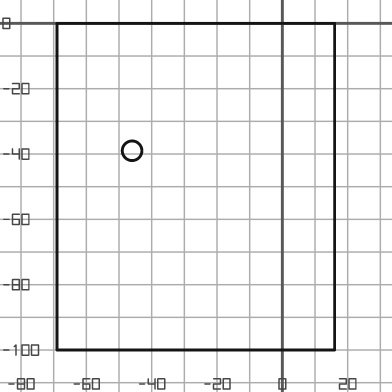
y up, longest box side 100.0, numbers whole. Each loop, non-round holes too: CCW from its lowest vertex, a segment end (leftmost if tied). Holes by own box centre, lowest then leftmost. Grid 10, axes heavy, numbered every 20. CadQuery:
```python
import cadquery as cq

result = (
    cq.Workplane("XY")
    .moveTo(-69.0, -100.0)
    .lineTo(16.0, -100.0)
    .lineTo(16.0, 0.0)
    .lineTo(-69.0, 0.0)
    .close()
    .moveTo(-46.0, -39.0)
    .circle(3.0)
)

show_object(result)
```